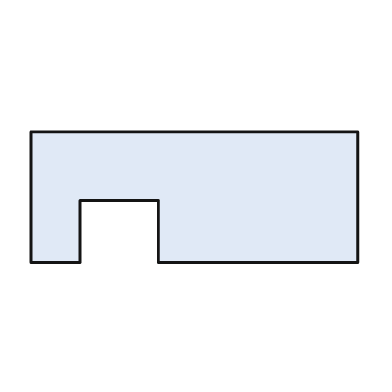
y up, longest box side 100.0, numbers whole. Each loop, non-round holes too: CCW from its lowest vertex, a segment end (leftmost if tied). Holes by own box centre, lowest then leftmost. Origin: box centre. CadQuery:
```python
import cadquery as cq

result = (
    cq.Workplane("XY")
    .moveTo(-50.0, -20.0)
    .lineTo(-35.0, -20.0)
    .lineTo(-35.0, -1.0)
    .lineTo(-11.0, -1.0)
    .lineTo(-11.0, -20.0)
    .lineTo(50.0, -20.0)
    .lineTo(50.0, 20.0)
    .lineTo(-50.0, 20.0)
    .close()
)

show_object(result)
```